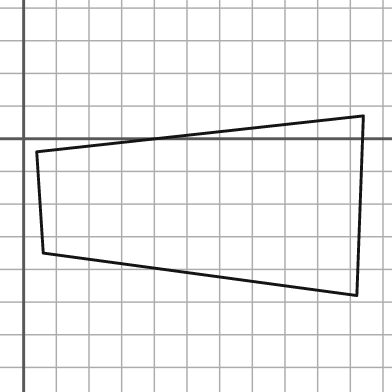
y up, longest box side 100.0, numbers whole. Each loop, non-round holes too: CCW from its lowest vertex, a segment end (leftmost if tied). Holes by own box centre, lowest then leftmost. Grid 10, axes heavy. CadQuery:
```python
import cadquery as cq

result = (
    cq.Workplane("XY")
    .moveTo(102.0, -48.0)
    .lineTo(104.0, 7.0)
    .lineTo(4.0, -4.0)
    .lineTo(6.0, -35.0)
    .close()
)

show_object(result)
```